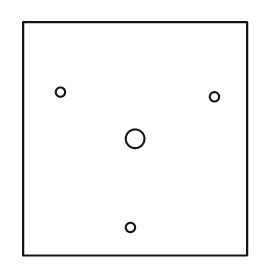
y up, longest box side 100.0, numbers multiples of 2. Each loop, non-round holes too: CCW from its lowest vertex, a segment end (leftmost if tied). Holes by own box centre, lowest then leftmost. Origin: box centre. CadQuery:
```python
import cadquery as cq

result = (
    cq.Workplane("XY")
    .moveTo(-48.0, -50.0)
    .lineTo(48.0, -50.0)
    .lineTo(48.0, 50.0)
    .lineTo(-48.0, 50.0)
    .close()
    .moveTo(-2.0, -38.0)
    .circle(2.0)
    .moveTo(0.0, 0.0)
    .circle(4.0)
    .moveTo(34.0, 18.0)
    .circle(2.0)
    .moveTo(-32.0, 20.0)
    .circle(2.0)
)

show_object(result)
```